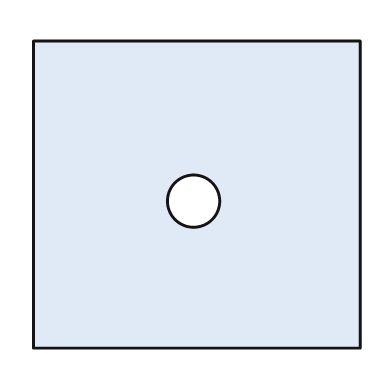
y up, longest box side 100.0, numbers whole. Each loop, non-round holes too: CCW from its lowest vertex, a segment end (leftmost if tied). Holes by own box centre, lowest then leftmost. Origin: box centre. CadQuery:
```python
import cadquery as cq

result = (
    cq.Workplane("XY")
    .moveTo(-50.0, -47.0)
    .lineTo(50.0, -47.0)
    .lineTo(50.0, 47.0)
    .lineTo(-50.0, 47.0)
    .close()
    .moveTo(-1.0, -2.0)
    .circle(8.0)
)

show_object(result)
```